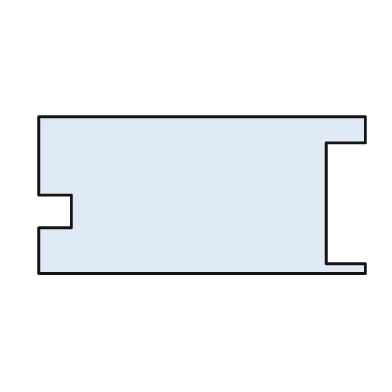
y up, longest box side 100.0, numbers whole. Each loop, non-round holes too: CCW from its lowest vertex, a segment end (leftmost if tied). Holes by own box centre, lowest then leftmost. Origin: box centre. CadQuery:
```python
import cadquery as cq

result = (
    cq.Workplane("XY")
    .moveTo(-50.0, -24.0)
    .lineTo(50.0, -24.0)
    .lineTo(50.0, -21.0)
    .lineTo(38.0, -21.0)
    .lineTo(38.0, 16.0)
    .lineTo(50.0, 16.0)
    .lineTo(50.0, 24.0)
    .lineTo(-50.0, 24.0)
    .lineTo(-50.0, 0.0)
    .lineTo(-40.0, 0.0)
    .lineTo(-40.0, -10.0)
    .lineTo(-50.0, -10.0)
    .close()
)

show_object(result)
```